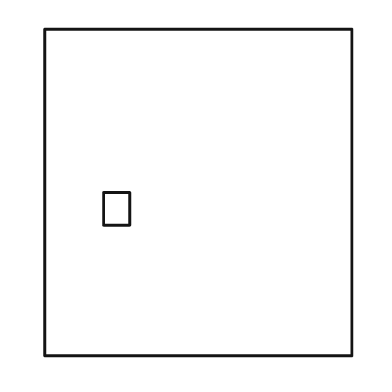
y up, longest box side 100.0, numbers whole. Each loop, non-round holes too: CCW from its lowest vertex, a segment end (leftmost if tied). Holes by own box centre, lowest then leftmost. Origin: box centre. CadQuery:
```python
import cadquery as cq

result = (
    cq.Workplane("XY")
    .moveTo(-47.0, -50.0)
    .lineTo(47.0, -50.0)
    .lineTo(47.0, 50.0)
    .lineTo(-47.0, 50.0)
    .close()
    .moveTo(-29.0, -10.0)
    .lineTo(-21.0, -10.0)
    .lineTo(-21.0, 0.0)
    .lineTo(-29.0, 0.0)
    .close()
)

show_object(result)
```